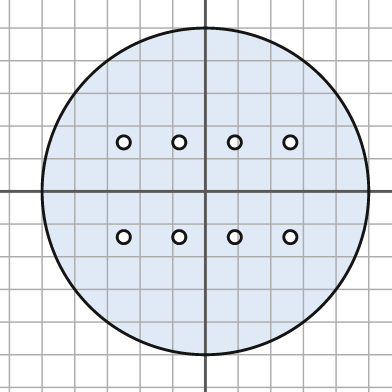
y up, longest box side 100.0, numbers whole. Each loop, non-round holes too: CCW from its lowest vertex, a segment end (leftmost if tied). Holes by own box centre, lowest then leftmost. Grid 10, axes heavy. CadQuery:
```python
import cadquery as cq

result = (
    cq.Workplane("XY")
    .moveTo(0.0, 0.0)
    .circle(50.0)
    .moveTo(-25.0, -14.0)
    .circle(2.0)
    .moveTo(-8.0, -14.0)
    .circle(2.0)
    .moveTo(9.0, -14.0)
    .circle(2.0)
    .moveTo(26.0, -14.0)
    .circle(2.0)
    .moveTo(-25.0, 15.0)
    .circle(2.0)
    .moveTo(-8.0, 15.0)
    .circle(2.0)
    .moveTo(9.0, 15.0)
    .circle(2.0)
    .moveTo(26.0, 15.0)
    .circle(2.0)
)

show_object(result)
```